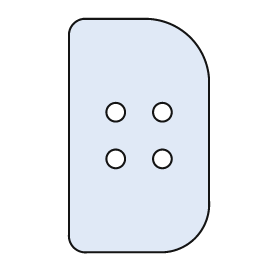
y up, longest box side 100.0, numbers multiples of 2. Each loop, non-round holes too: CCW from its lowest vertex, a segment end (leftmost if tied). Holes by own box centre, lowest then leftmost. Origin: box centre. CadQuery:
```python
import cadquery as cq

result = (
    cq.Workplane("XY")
    .moveTo(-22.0, -50.0)
    .lineTo(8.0, -50.0)
    .threePointArc((24.0, -44.0), (30.0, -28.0))
    .lineTo(30.0, 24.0)
    .threePointArc((22.0, 42.0), (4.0, 50.0))
    .lineTo(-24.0, 50.0)
    .threePointArc((-28.0, 48.0), (-30.0, 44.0))
    .lineTo(-30.0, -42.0)
    .threePointArc((-28.0, -48.0), (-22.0, -50.0))
    .close()
    .moveTo(-10.0, -10.0)
    .circle(4.0)
    .moveTo(10.0, -10.0)
    .circle(4.0)
    .moveTo(-10.0, 10.0)
    .circle(4.0)
    .moveTo(10.0, 10.0)
    .circle(4.0)
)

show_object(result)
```